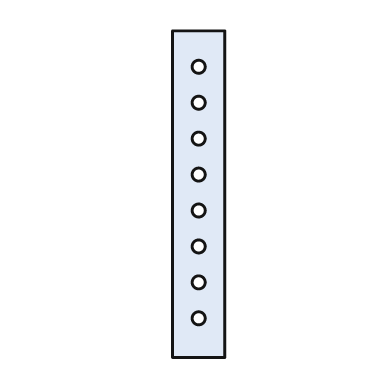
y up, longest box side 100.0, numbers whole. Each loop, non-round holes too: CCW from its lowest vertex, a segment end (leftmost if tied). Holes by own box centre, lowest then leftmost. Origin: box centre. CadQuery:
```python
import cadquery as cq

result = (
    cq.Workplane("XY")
    .moveTo(-8.0, -50.0)
    .lineTo(8.0, -50.0)
    .lineTo(8.0, 50.0)
    .lineTo(-8.0, 50.0)
    .close()
    .moveTo(0.0, -38.0)
    .circle(2.0)
    .moveTo(0.0, -27.0)
    .circle(2.0)
    .moveTo(0.0, -16.0)
    .circle(2.0)
    .moveTo(0.0, -5.0)
    .circle(2.0)
    .moveTo(0.0, 6.0)
    .circle(2.0)
    .moveTo(0.0, 17.0)
    .circle(2.0)
    .moveTo(0.0, 28.0)
    .circle(2.0)
    .moveTo(0.0, 39.0)
    .circle(2.0)
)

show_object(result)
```